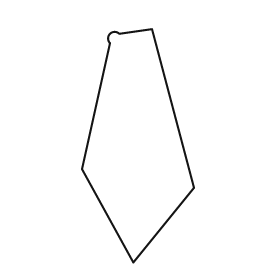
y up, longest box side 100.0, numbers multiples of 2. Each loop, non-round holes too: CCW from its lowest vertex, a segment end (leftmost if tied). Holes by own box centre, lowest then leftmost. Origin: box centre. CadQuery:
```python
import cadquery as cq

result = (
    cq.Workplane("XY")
    .moveTo(-2.0, -50.0)
    .lineTo(24.0, -18.0)
    .lineTo(6.0, 50.0)
    .lineTo(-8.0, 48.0)
    .threePointArc((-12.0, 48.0), (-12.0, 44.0))
    .lineTo(-24.0, -10.0)
    .close()
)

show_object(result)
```